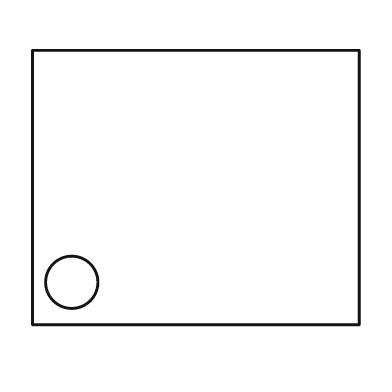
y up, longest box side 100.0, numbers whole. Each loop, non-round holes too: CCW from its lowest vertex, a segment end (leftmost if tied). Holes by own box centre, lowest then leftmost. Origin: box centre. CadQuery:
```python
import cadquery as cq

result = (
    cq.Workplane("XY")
    .moveTo(-50.0, -42.0)
    .lineTo(50.0, -42.0)
    .lineTo(50.0, 42.0)
    .lineTo(-50.0, 42.0)
    .close()
    .moveTo(-38.0, -29.0)
    .circle(8.0)
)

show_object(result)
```